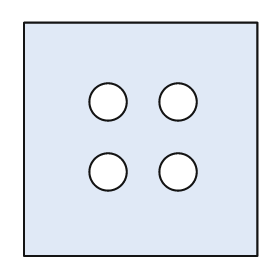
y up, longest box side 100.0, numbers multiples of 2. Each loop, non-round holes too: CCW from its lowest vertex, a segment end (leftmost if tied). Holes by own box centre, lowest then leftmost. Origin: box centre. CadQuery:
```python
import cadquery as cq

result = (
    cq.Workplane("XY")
    .moveTo(-50.0, -50.0)
    .lineTo(50.0, -50.0)
    .lineTo(50.0, 50.0)
    .lineTo(-50.0, 50.0)
    .close()
    .moveTo(-14.0, -14.0)
    .circle(8.0)
    .moveTo(16.0, -14.0)
    .circle(8.0)
    .moveTo(-14.0, 16.0)
    .circle(8.0)
    .moveTo(16.0, 16.0)
    .circle(8.0)
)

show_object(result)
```